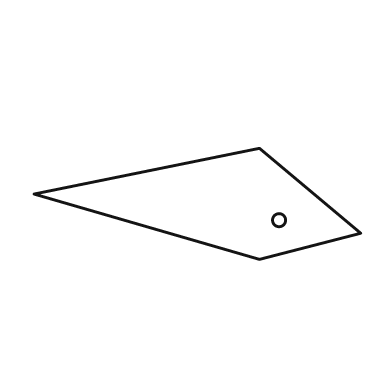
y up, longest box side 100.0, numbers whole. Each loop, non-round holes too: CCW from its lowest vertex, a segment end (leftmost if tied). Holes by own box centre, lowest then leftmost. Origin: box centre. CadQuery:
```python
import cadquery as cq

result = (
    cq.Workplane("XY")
    .moveTo(19.0, -17.0)
    .lineTo(50.0, -9.0)
    .lineTo(19.0, 17.0)
    .lineTo(-50.0, 3.0)
    .close()
    .moveTo(25.0, -5.0)
    .circle(2.0)
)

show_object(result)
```